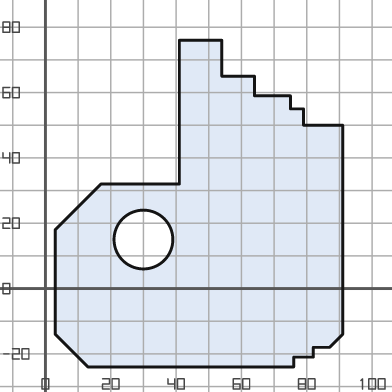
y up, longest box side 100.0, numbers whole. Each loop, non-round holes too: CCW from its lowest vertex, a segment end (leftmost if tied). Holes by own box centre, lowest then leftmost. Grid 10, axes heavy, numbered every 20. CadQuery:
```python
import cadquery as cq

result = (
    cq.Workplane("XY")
    .moveTo(13.0, -24.0)
    .lineTo(76.0, -24.0)
    .lineTo(76.0, -21.0)
    .lineTo(82.0, -21.0)
    .lineTo(82.0, -18.0)
    .lineTo(87.0, -18.0)
    .lineTo(91.0, -14.0)
    .lineTo(91.0, 50.0)
    .lineTo(79.0, 50.0)
    .lineTo(79.0, 55.0)
    .lineTo(75.0, 55.0)
    .lineTo(75.0, 59.0)
    .lineTo(64.0, 59.0)
    .lineTo(64.0, 65.0)
    .lineTo(54.0, 65.0)
    .lineTo(54.0, 76.0)
    .lineTo(41.0, 76.0)
    .lineTo(41.0, 32.0)
    .lineTo(17.0, 32.0)
    .lineTo(3.0, 18.0)
    .lineTo(3.0, -14.0)
    .close()
    .moveTo(30.0, 15.0)
    .circle(9.0)
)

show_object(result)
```